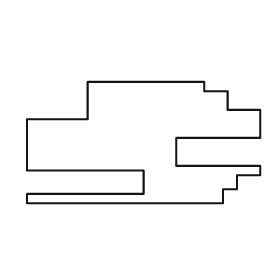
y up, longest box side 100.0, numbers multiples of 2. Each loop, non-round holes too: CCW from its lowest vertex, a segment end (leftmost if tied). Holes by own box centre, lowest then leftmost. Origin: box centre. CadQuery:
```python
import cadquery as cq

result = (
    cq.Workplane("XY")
    .moveTo(-50.0, -26.0)
    .lineTo(34.0, -26.0)
    .lineTo(34.0, -20.0)
    .lineTo(40.0, -20.0)
    .lineTo(40.0, -14.0)
    .lineTo(50.0, -14.0)
    .lineTo(50.0, -10.0)
    .lineTo(14.0, -10.0)
    .lineTo(14.0, 2.0)
    .lineTo(50.0, 2.0)
    .lineTo(50.0, 14.0)
    .lineTo(36.0, 14.0)
    .lineTo(36.0, 22.0)
    .lineTo(26.0, 22.0)
    .lineTo(26.0, 26.0)
    .lineTo(-24.0, 26.0)
    .lineTo(-24.0, 10.0)
    .lineTo(-50.0, 10.0)
    .lineTo(-50.0, -12.0)
    .lineTo(0.0, -12.0)
    .lineTo(0.0, -22.0)
    .lineTo(-50.0, -22.0)
    .close()
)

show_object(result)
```